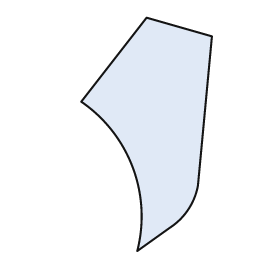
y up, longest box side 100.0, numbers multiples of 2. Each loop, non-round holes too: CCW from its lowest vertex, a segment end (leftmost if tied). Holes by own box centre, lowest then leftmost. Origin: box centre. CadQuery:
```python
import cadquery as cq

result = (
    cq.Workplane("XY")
    .moveTo(-4.0, -50.0)
    .lineTo(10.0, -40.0)
    .threePointArc((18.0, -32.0), (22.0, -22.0))
    .lineTo(28.0, 42.0)
    .lineTo(0.0, 50.0)
    .lineTo(-28.0, 14.0)
    .threePointArc((-6.0, -14.0), (-4.0, -50.0))
    .close()
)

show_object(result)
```